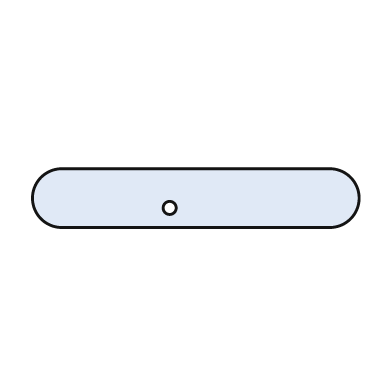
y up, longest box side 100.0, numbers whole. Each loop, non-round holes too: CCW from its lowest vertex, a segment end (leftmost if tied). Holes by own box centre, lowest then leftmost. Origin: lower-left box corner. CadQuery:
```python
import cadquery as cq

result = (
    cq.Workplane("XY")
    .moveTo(9.0, 0.0)
    .lineTo(91.0, 0.0)
    .threePointArc((100.0, 9.0), (91.0, 18.0))
    .lineTo(9.0, 18.0)
    .threePointArc((0.0, 9.0), (9.0, 0.0))
    .close()
    .moveTo(42.0, 6.0)
    .circle(2.0)
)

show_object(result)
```